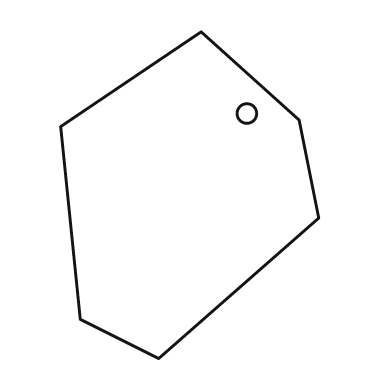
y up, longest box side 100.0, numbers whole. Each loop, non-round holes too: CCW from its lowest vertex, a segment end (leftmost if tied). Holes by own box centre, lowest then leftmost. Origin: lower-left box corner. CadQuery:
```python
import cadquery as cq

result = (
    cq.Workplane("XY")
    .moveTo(30.0, 0.0)
    .lineTo(79.0, 43.0)
    .lineTo(73.0, 73.0)
    .lineTo(43.0, 100.0)
    .lineTo(0.0, 71.0)
    .lineTo(6.0, 12.0)
    .close()
    .moveTo(57.0, 75.0)
    .circle(3.0)
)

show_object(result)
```